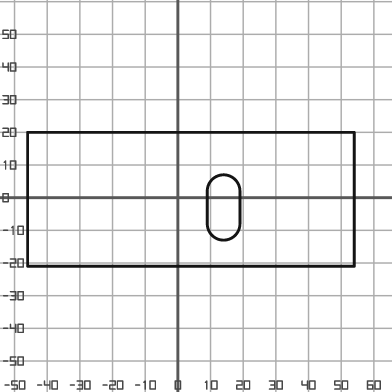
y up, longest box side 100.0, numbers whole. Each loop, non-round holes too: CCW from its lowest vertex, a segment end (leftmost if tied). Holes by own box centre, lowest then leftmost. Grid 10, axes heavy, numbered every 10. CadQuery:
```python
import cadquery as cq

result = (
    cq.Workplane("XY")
    .moveTo(-46.0, -21.0)
    .lineTo(54.0, -21.0)
    .lineTo(54.0, 20.0)
    .lineTo(-46.0, 20.0)
    .close()
    .moveTo(9.0, -8.0)
    .threePointArc((14.0, -13.0), (19.0, -8.0))
    .lineTo(19.0, 2.0)
    .threePointArc((14.0, 7.0), (9.0, 2.0))
    .close()
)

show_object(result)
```